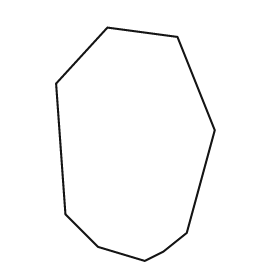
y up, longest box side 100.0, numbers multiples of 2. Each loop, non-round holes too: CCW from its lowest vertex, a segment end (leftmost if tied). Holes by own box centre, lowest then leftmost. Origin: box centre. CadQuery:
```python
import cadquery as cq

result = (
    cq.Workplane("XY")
    .moveTo(4.0, -50.0)
    .lineTo(12.0, -46.0)
    .lineTo(22.0, -38.0)
    .lineTo(34.0, 6.0)
    .lineTo(18.0, 46.0)
    .lineTo(-12.0, 50.0)
    .lineTo(-34.0, 26.0)
    .lineTo(-30.0, -30.0)
    .lineTo(-16.0, -44.0)
    .close()
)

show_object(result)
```